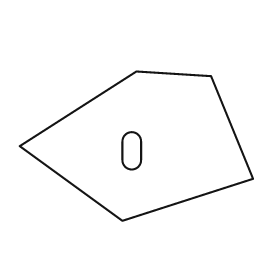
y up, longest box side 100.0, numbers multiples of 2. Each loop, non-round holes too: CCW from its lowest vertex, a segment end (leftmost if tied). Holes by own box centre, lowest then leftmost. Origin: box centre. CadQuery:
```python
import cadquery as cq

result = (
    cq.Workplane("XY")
    .moveTo(-6.0, -32.0)
    .lineTo(50.0, -14.0)
    .lineTo(32.0, 30.0)
    .lineTo(0.0, 32.0)
    .lineTo(-50.0, 0.0)
    .close()
    .moveTo(-6.0, -6.0)
    .threePointArc((-2.0, -10.0), (2.0, -6.0))
    .lineTo(2.0, 2.0)
    .threePointArc((-2.0, 6.0), (-6.0, 2.0))
    .close()
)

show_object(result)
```